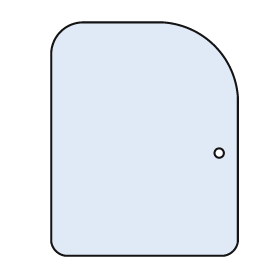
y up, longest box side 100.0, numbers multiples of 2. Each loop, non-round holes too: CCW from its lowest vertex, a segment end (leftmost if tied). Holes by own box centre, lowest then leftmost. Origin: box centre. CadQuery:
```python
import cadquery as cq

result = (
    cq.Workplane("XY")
    .moveTo(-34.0, -50.0)
    .lineTo(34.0, -50.0)
    .threePointArc((38.0, -48.0), (40.0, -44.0))
    .lineTo(40.0, 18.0)
    .threePointArc((30.0, 40.0), (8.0, 50.0))
    .lineTo(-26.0, 50.0)
    .threePointArc((-36.0, 46.0), (-40.0, 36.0))
    .lineTo(-40.0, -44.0)
    .threePointArc((-38.0, -48.0), (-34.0, -50.0))
    .close()
    .moveTo(32.0, -6.0)
    .circle(2.0)
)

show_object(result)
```